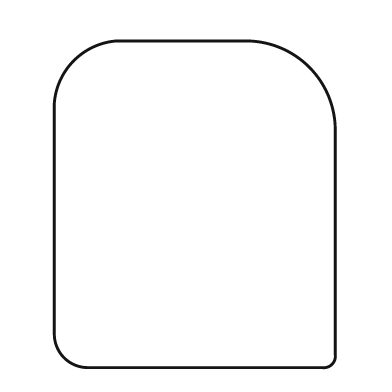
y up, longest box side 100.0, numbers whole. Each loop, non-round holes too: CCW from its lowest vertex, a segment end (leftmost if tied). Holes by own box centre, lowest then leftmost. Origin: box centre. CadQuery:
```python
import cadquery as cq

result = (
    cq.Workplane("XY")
    .moveTo(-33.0, -50.0)
    .lineTo(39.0, -50.0)
    .threePointArc((42.0, -49.0), (43.0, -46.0))
    .lineTo(43.0, 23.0)
    .threePointArc((35.0, 42.0), (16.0, 50.0))
    .lineTo(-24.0, 50.0)
    .threePointArc((-37.0, 44.0), (-43.0, 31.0))
    .lineTo(-43.0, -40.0)
    .threePointArc((-40.0, -47.0), (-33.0, -50.0))
    .close()
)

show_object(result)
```